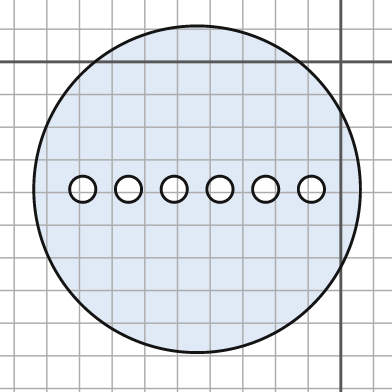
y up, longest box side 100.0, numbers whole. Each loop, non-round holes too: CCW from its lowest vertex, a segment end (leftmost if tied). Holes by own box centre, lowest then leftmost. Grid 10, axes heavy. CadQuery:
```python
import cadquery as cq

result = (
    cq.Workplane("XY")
    .moveTo(-44.0, -39.0)
    .circle(50.0)
    .moveTo(-79.0, -39.0)
    .circle(4.0)
    .moveTo(-65.0, -39.0)
    .circle(4.0)
    .moveTo(-51.0, -39.0)
    .circle(4.0)
    .moveTo(-37.0, -39.0)
    .circle(4.0)
    .moveTo(-23.0, -39.0)
    .circle(4.0)
    .moveTo(-9.0, -39.0)
    .circle(4.0)
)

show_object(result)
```